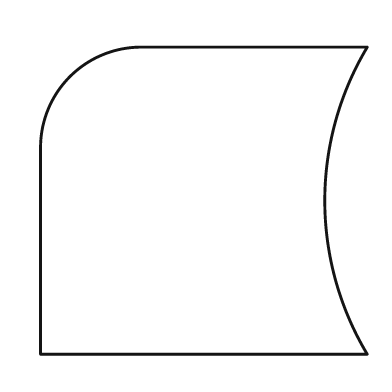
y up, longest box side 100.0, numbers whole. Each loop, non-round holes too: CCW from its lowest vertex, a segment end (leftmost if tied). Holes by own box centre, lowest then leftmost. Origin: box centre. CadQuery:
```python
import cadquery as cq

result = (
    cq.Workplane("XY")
    .moveTo(-50.0, -47.0)
    .lineTo(50.0, -47.0)
    .threePointArc((37.0, 0.0), (50.0, 47.0))
    .lineTo(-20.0, 47.0)
    .threePointArc((-41.0, 38.0), (-50.0, 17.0))
    .close()
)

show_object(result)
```